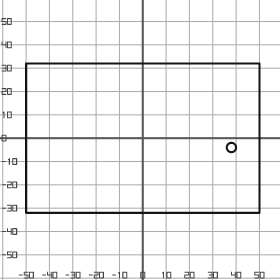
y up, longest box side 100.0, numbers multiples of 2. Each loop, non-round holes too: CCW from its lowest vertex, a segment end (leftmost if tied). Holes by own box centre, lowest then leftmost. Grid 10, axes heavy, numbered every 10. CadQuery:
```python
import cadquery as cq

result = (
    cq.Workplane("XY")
    .moveTo(-50.0, -32.0)
    .lineTo(50.0, -32.0)
    .lineTo(50.0, 32.0)
    .lineTo(-50.0, 32.0)
    .close()
    .moveTo(38.0, -4.0)
    .circle(2.0)
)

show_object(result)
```